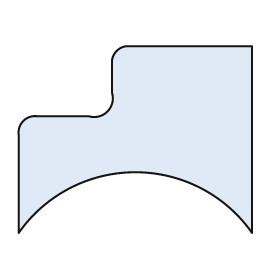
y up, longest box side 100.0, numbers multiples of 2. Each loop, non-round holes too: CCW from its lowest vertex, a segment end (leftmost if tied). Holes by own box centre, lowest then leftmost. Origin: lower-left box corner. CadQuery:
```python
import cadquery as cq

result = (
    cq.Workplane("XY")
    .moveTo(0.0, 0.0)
    .threePointArc((50.0, 26.0), (100.0, 0.0))
    .lineTo(100.0, 80.0)
    .lineTo(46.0, 80.0)
    .threePointArc((42.0, 78.0), (40.0, 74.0))
    .lineTo(40.0, 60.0)
    .threePointArc((38.0, 52.0), (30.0, 50.0))
    .lineTo(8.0, 50.0)
    .threePointArc((2.0, 48.0), (0.0, 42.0))
    .close()
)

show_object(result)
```